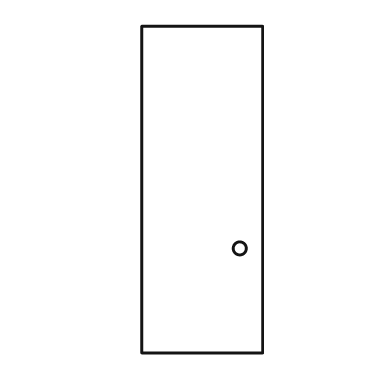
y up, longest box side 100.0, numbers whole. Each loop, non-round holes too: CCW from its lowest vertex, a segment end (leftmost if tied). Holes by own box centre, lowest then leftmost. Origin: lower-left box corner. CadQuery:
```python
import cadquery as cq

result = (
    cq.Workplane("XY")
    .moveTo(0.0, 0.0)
    .lineTo(37.0, 0.0)
    .lineTo(37.0, 100.0)
    .lineTo(0.0, 100.0)
    .close()
    .moveTo(30.0, 32.0)
    .circle(2.0)
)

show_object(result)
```